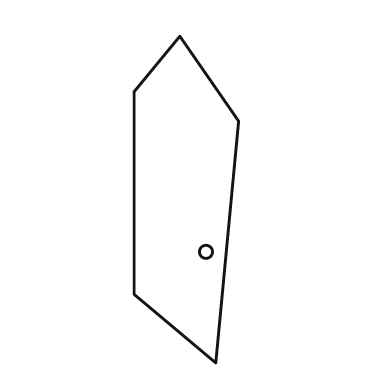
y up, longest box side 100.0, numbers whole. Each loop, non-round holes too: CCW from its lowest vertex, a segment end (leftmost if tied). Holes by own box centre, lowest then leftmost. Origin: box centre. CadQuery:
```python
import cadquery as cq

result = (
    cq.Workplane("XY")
    .moveTo(9.0, -50.0)
    .lineTo(16.0, 24.0)
    .lineTo(-2.0, 50.0)
    .lineTo(-16.0, 33.0)
    .lineTo(-16.0, -29.0)
    .close()
    .moveTo(6.0, -16.0)
    .circle(2.0)
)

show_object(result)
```